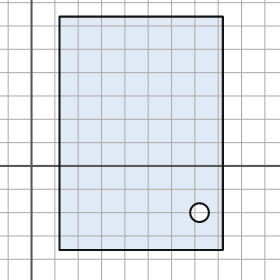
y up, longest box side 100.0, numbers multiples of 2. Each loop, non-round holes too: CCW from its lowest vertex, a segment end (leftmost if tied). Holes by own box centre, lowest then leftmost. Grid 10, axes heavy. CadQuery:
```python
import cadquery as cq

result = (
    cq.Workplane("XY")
    .moveTo(12.0, -36.0)
    .lineTo(82.0, -36.0)
    .lineTo(82.0, 64.0)
    .lineTo(12.0, 64.0)
    .close()
    .moveTo(72.0, -20.0)
    .circle(4.0)
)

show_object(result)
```